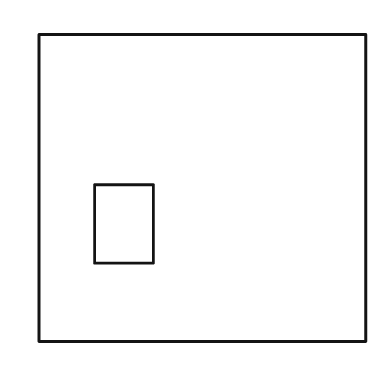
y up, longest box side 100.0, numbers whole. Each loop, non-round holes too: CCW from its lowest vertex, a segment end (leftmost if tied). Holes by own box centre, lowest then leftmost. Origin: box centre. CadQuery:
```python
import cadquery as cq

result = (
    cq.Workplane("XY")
    .moveTo(-50.0, -47.0)
    .lineTo(50.0, -47.0)
    .lineTo(50.0, 47.0)
    .lineTo(-50.0, 47.0)
    .close()
    .moveTo(-33.0, -23.0)
    .lineTo(-15.0, -23.0)
    .lineTo(-15.0, 1.0)
    .lineTo(-33.0, 1.0)
    .close()
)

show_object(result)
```